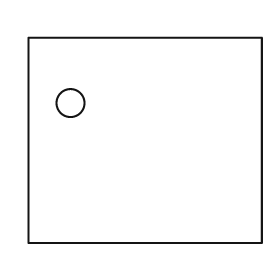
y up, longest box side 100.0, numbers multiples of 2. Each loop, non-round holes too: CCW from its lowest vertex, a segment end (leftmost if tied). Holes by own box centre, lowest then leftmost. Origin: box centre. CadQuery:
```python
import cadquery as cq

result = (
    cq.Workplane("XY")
    .moveTo(-50.0, -44.0)
    .lineTo(50.0, -44.0)
    .lineTo(50.0, 44.0)
    .lineTo(-50.0, 44.0)
    .close()
    .moveTo(-32.0, 16.0)
    .circle(6.0)
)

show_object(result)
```